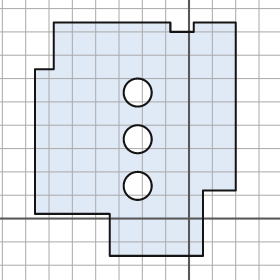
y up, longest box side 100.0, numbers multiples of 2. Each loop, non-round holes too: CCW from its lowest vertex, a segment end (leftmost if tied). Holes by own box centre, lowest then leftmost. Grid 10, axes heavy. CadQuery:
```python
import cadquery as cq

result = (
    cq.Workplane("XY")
    .moveTo(-34.0, -16.0)
    .lineTo(6.0, -16.0)
    .lineTo(6.0, 12.0)
    .lineTo(20.0, 12.0)
    .lineTo(20.0, 84.0)
    .lineTo(2.0, 84.0)
    .lineTo(2.0, 80.0)
    .lineTo(-8.0, 80.0)
    .lineTo(-8.0, 84.0)
    .lineTo(-58.0, 84.0)
    .lineTo(-58.0, 64.0)
    .lineTo(-66.0, 64.0)
    .lineTo(-66.0, 2.0)
    .lineTo(-34.0, 2.0)
    .close()
    .moveTo(-22.0, 14.0)
    .circle(6.0)
    .moveTo(-22.0, 34.0)
    .circle(6.0)
    .moveTo(-22.0, 54.0)
    .circle(6.0)
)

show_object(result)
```